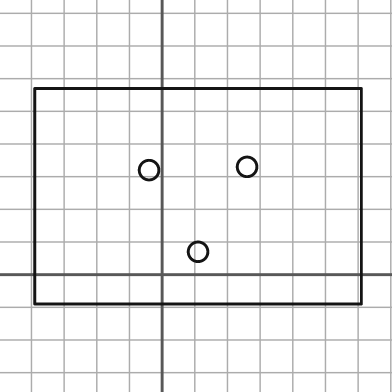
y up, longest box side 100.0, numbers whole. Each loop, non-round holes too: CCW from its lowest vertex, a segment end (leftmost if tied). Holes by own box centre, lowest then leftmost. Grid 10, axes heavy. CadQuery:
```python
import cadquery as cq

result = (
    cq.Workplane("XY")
    .moveTo(-39.0, -9.0)
    .lineTo(61.0, -9.0)
    .lineTo(61.0, 57.0)
    .lineTo(-39.0, 57.0)
    .close()
    .moveTo(11.0, 7.0)
    .circle(3.0)
    .moveTo(-4.0, 32.0)
    .circle(3.0)
    .moveTo(26.0, 33.0)
    .circle(3.0)
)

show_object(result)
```